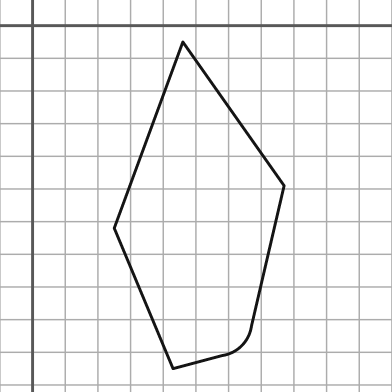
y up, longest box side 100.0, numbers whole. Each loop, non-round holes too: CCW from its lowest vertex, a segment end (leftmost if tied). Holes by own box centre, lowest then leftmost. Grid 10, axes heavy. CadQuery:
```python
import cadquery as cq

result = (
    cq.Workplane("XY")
    .moveTo(43.0, -105.0)
    .lineTo(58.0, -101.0)
    .threePointArc((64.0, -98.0), (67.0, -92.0))
    .lineTo(77.0, -49.0)
    .lineTo(46.0, -5.0)
    .lineTo(25.0, -62.0)
    .close()
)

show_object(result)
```